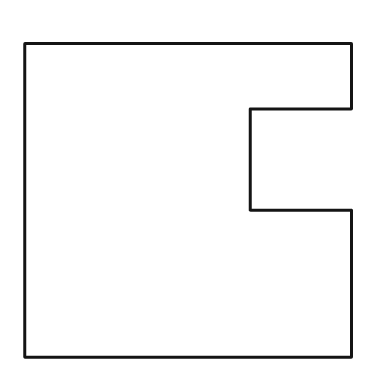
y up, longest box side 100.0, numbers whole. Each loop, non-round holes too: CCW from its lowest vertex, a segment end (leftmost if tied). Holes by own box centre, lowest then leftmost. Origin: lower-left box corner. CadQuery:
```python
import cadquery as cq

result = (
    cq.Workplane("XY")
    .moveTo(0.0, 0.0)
    .lineTo(100.0, 0.0)
    .lineTo(100.0, 45.0)
    .lineTo(69.0, 45.0)
    .lineTo(69.0, 76.0)
    .lineTo(100.0, 76.0)
    .lineTo(100.0, 96.0)
    .lineTo(0.0, 96.0)
    .close()
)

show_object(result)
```